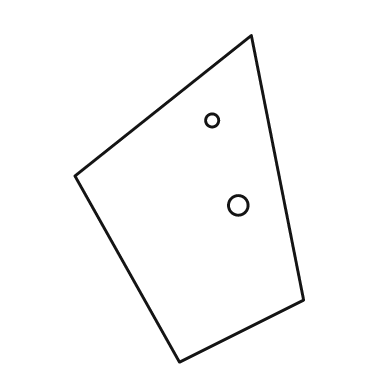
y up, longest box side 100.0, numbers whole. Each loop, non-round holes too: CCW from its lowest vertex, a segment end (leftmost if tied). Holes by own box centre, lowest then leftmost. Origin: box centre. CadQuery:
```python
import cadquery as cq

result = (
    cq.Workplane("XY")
    .moveTo(-3.0, -50.0)
    .lineTo(35.0, -31.0)
    .lineTo(19.0, 50.0)
    .lineTo(-35.0, 7.0)
    .close()
    .moveTo(15.0, -2.0)
    .circle(3.0)
    .moveTo(7.0, 24.0)
    .circle(2.0)
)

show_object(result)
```